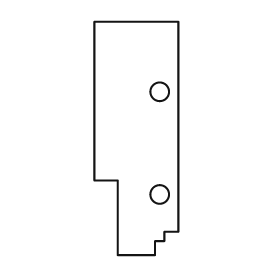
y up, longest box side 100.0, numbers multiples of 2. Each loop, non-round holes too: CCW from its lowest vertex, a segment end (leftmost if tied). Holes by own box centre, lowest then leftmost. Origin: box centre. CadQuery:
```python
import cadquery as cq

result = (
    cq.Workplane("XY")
    .moveTo(-8.0, -50.0)
    .lineTo(8.0, -50.0)
    .lineTo(8.0, -44.0)
    .lineTo(12.0, -44.0)
    .lineTo(12.0, -40.0)
    .lineTo(18.0, -40.0)
    .lineTo(18.0, 50.0)
    .lineTo(-18.0, 50.0)
    .lineTo(-18.0, -18.0)
    .lineTo(-8.0, -18.0)
    .close()
    .moveTo(10.0, -24.0)
    .circle(4.0)
    .moveTo(10.0, 20.0)
    .circle(4.0)
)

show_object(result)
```